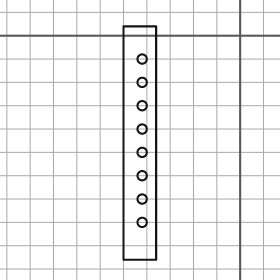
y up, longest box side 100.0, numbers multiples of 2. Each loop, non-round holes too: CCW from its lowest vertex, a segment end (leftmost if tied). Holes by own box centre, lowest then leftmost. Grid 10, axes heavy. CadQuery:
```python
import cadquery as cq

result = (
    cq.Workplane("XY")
    .moveTo(-50.0, -96.0)
    .lineTo(-36.0, -96.0)
    .lineTo(-36.0, 4.0)
    .lineTo(-50.0, 4.0)
    .close()
    .moveTo(-42.0, -80.0)
    .circle(2.0)
    .moveTo(-42.0, -70.0)
    .circle(2.0)
    .moveTo(-42.0, -60.0)
    .circle(2.0)
    .moveTo(-42.0, -50.0)
    .circle(2.0)
    .moveTo(-42.0, -40.0)
    .circle(2.0)
    .moveTo(-42.0, -30.0)
    .circle(2.0)
    .moveTo(-42.0, -20.0)
    .circle(2.0)
    .moveTo(-42.0, -10.0)
    .circle(2.0)
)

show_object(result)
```